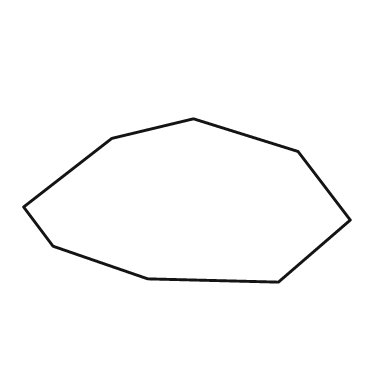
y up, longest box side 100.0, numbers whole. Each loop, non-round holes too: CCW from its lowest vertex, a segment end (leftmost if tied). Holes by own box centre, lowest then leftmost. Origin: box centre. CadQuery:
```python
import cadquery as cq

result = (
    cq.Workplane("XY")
    .moveTo(28.0, -25.0)
    .lineTo(50.0, -6.0)
    .lineTo(34.0, 15.0)
    .lineTo(2.0, 25.0)
    .lineTo(-23.0, 19.0)
    .lineTo(-50.0, -2.0)
    .lineTo(-41.0, -14.0)
    .lineTo(-12.0, -24.0)
    .close()
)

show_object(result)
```